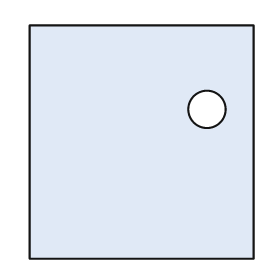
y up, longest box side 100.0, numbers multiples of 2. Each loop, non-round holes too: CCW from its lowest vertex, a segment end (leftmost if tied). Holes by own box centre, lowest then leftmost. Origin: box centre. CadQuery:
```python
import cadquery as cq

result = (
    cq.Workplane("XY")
    .moveTo(-48.0, -50.0)
    .lineTo(48.0, -50.0)
    .lineTo(48.0, 50.0)
    .lineTo(-48.0, 50.0)
    .close()
    .moveTo(28.0, 14.0)
    .circle(8.0)
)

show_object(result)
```